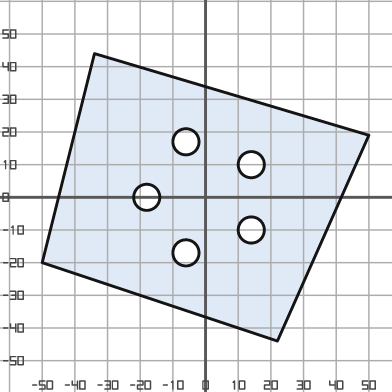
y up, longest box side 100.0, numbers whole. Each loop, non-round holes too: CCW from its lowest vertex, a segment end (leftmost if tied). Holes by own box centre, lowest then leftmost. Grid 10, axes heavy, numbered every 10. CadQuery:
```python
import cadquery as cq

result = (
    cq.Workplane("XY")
    .moveTo(22.0, -44.0)
    .lineTo(50.0, 19.0)
    .lineTo(-34.0, 44.0)
    .lineTo(-50.0, -20.0)
    .close()
    .moveTo(-6.0, -17.0)
    .circle(4.0)
    .moveTo(14.0, -10.0)
    .circle(4.0)
    .moveTo(-18.0, 0.0)
    .circle(4.0)
    .moveTo(14.0, 10.0)
    .circle(4.0)
    .moveTo(-6.0, 17.0)
    .circle(4.0)
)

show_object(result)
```